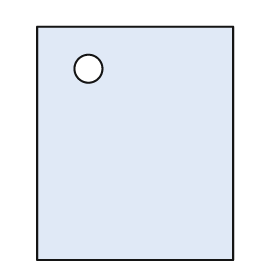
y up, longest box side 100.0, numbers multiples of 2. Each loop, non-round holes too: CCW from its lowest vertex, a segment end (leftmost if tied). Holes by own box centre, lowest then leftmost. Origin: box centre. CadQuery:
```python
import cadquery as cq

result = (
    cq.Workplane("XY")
    .moveTo(-42.0, -50.0)
    .lineTo(42.0, -50.0)
    .lineTo(42.0, 50.0)
    .lineTo(-42.0, 50.0)
    .close()
    .moveTo(-20.0, 32.0)
    .circle(6.0)
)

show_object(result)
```